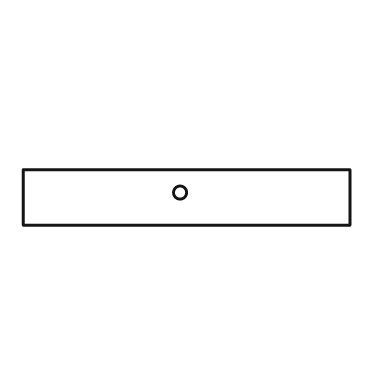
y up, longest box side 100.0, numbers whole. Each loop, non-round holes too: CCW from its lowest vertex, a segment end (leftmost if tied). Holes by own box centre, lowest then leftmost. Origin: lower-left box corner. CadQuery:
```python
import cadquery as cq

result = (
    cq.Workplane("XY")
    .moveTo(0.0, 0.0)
    .lineTo(100.0, 0.0)
    .lineTo(100.0, 17.0)
    .lineTo(0.0, 17.0)
    .close()
    .moveTo(48.0, 10.0)
    .circle(2.0)
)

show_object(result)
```